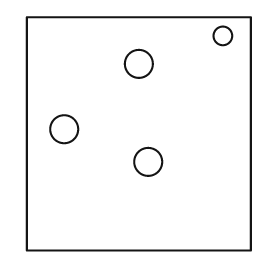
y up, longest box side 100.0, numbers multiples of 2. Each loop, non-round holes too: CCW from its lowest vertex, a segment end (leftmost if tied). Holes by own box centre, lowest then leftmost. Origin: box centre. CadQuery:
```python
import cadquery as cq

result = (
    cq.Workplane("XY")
    .moveTo(-48.0, -50.0)
    .lineTo(48.0, -50.0)
    .lineTo(48.0, 50.0)
    .lineTo(-48.0, 50.0)
    .close()
    .moveTo(4.0, -12.0)
    .circle(6.0)
    .moveTo(-32.0, 2.0)
    .circle(6.0)
    .moveTo(0.0, 30.0)
    .circle(6.0)
    .moveTo(36.0, 42.0)
    .circle(4.0)
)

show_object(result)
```